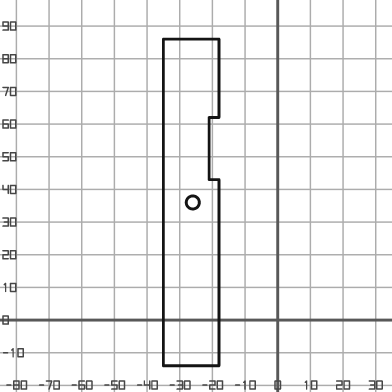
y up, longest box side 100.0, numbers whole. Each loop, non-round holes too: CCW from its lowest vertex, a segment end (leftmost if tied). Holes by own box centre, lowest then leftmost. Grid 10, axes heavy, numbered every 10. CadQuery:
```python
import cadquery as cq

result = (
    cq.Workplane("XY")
    .moveTo(-35.0, -14.0)
    .lineTo(-18.0, -14.0)
    .lineTo(-18.0, 43.0)
    .lineTo(-21.0, 43.0)
    .lineTo(-21.0, 62.0)
    .lineTo(-18.0, 62.0)
    .lineTo(-18.0, 86.0)
    .lineTo(-35.0, 86.0)
    .close()
    .moveTo(-26.0, 36.0)
    .circle(2.0)
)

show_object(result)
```